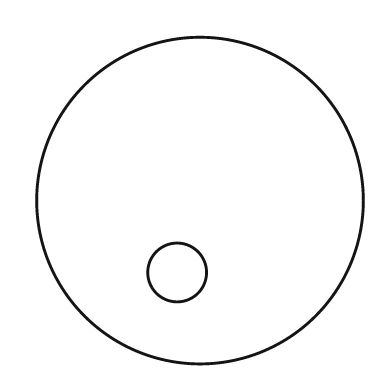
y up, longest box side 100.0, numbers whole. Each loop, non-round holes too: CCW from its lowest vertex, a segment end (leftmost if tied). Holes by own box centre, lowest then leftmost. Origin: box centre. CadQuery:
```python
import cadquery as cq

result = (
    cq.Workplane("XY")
    .moveTo(0.0, 0.0)
    .circle(50.0)
    .moveTo(-7.0, -22.0)
    .circle(9.0)
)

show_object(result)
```